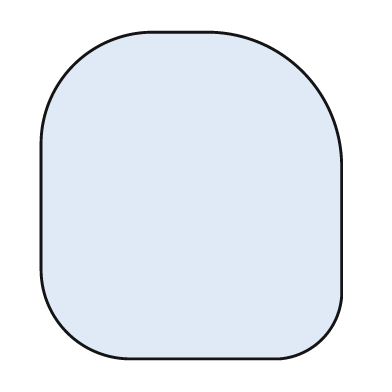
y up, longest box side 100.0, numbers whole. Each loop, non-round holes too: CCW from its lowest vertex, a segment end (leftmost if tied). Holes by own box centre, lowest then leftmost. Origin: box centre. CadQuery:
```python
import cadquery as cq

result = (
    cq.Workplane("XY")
    .moveTo(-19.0, -50.0)
    .lineTo(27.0, -50.0)
    .threePointArc((40.0, -44.0), (46.0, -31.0))
    .lineTo(46.0, 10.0)
    .threePointArc((34.0, 38.0), (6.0, 50.0))
    .lineTo(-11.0, 50.0)
    .threePointArc((-36.0, 40.0), (-46.0, 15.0))
    .lineTo(-46.0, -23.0)
    .threePointArc((-38.0, -42.0), (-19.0, -50.0))
    .close()
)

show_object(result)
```